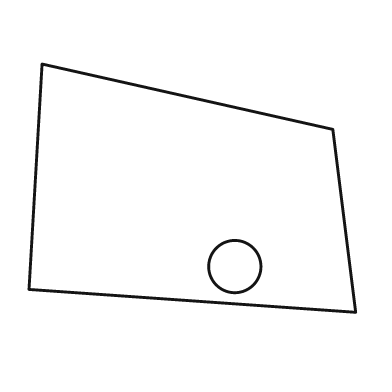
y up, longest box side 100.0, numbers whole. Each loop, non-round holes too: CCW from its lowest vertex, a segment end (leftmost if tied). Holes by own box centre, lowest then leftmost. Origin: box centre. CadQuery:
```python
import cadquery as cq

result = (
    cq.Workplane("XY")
    .moveTo(50.0, -38.0)
    .lineTo(43.0, 18.0)
    .lineTo(-46.0, 38.0)
    .lineTo(-50.0, -31.0)
    .close()
    .moveTo(13.0, -24.0)
    .circle(8.0)
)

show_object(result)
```